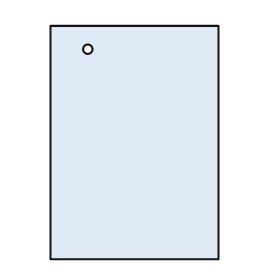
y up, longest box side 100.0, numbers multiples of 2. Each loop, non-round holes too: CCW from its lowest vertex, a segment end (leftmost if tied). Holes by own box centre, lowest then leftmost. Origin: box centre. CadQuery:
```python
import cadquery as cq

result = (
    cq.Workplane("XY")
    .moveTo(-36.0, -50.0)
    .lineTo(36.0, -50.0)
    .lineTo(36.0, 50.0)
    .lineTo(-36.0, 50.0)
    .close()
    .moveTo(-20.0, 40.0)
    .circle(2.0)
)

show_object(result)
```